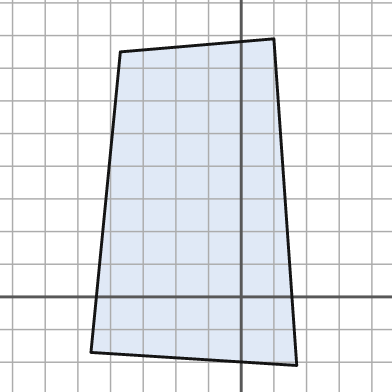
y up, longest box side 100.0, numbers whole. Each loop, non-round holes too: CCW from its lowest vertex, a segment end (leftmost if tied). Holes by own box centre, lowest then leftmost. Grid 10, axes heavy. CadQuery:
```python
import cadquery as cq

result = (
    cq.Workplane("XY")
    .moveTo(17.0, -21.0)
    .lineTo(10.0, 79.0)
    .lineTo(-37.0, 75.0)
    .lineTo(-46.0, -17.0)
    .close()
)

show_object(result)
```